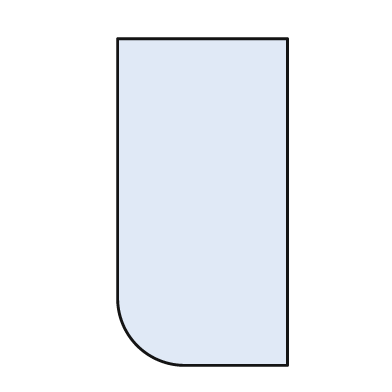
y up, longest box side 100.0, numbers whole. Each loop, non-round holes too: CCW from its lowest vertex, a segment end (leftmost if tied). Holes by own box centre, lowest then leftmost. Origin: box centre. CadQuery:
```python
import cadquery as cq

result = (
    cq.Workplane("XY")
    .moveTo(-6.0, -50.0)
    .lineTo(26.0, -50.0)
    .lineTo(26.0, 50.0)
    .lineTo(-26.0, 50.0)
    .lineTo(-26.0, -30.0)
    .threePointArc((-20.0, -44.0), (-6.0, -50.0))
    .close()
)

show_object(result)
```